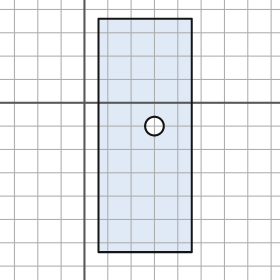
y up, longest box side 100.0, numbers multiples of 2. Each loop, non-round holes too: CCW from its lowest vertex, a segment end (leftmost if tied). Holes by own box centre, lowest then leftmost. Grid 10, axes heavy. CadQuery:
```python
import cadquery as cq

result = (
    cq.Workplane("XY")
    .moveTo(6.0, -64.0)
    .lineTo(46.0, -64.0)
    .lineTo(46.0, 36.0)
    .lineTo(6.0, 36.0)
    .close()
    .moveTo(30.0, -10.0)
    .circle(4.0)
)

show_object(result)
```